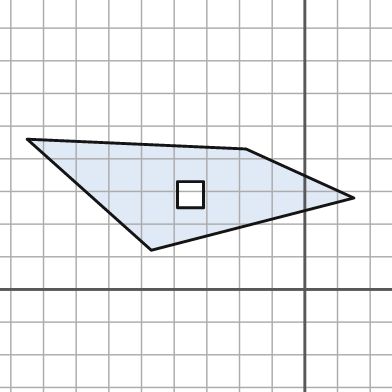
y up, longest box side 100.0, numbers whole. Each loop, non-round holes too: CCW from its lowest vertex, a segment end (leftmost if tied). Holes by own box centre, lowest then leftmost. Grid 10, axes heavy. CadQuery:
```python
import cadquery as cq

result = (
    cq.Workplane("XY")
    .moveTo(-47.0, 12.0)
    .lineTo(15.0, 28.0)
    .lineTo(-18.0, 43.0)
    .lineTo(-85.0, 46.0)
    .close()
    .moveTo(-39.0, 25.0)
    .lineTo(-31.0, 25.0)
    .lineTo(-31.0, 33.0)
    .lineTo(-39.0, 33.0)
    .close()
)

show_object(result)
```